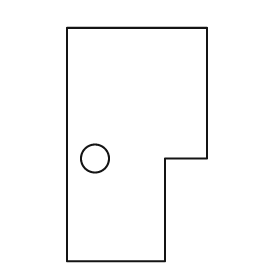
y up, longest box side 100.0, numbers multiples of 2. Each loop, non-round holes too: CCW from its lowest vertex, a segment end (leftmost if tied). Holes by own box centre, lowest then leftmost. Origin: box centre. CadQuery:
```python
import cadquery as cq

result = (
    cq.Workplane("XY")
    .moveTo(-30.0, -50.0)
    .lineTo(12.0, -50.0)
    .lineTo(12.0, -6.0)
    .lineTo(30.0, -6.0)
    .lineTo(30.0, 50.0)
    .lineTo(-30.0, 50.0)
    .close()
    .moveTo(-18.0, -6.0)
    .circle(6.0)
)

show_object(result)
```